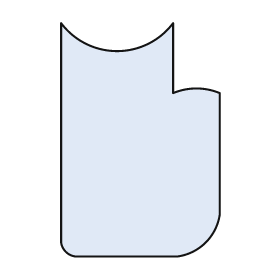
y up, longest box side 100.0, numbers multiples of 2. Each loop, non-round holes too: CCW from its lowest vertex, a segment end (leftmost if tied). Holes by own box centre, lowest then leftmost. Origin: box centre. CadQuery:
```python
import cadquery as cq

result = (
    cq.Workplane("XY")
    .moveTo(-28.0, -50.0)
    .lineTo(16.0, -50.0)
    .threePointArc((28.0, -44.0), (34.0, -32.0))
    .lineTo(34.0, 20.0)
    .threePointArc((24.0, 22.0), (14.0, 20.0))
    .lineTo(14.0, 50.0)
    .threePointArc((-10.0, 38.0), (-34.0, 50.0))
    .lineTo(-34.0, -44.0)
    .threePointArc((-32.0, -48.0), (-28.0, -50.0))
    .close()
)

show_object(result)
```